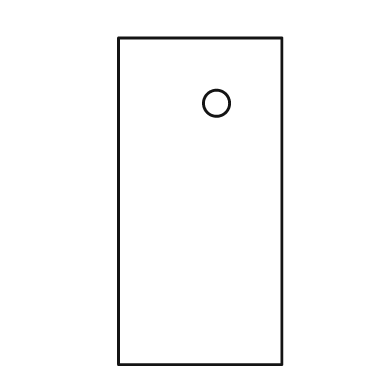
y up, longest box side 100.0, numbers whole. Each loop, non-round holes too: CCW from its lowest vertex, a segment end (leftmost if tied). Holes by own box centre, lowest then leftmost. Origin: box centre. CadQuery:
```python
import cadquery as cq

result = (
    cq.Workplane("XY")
    .moveTo(-25.0, -50.0)
    .lineTo(25.0, -50.0)
    .lineTo(25.0, 50.0)
    .lineTo(-25.0, 50.0)
    .close()
    .moveTo(5.0, 30.0)
    .circle(4.0)
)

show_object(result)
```